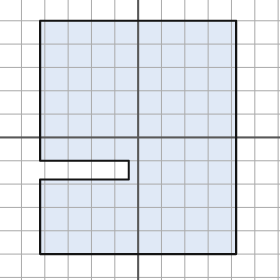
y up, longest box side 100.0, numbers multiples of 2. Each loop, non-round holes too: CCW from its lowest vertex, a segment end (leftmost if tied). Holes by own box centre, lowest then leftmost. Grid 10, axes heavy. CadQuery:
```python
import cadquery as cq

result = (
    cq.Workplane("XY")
    .moveTo(-42.0, -50.0)
    .lineTo(42.0, -50.0)
    .lineTo(42.0, 50.0)
    .lineTo(-42.0, 50.0)
    .lineTo(-42.0, -10.0)
    .lineTo(-4.0, -10.0)
    .lineTo(-4.0, -18.0)
    .lineTo(-42.0, -18.0)
    .close()
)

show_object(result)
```